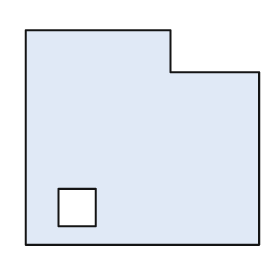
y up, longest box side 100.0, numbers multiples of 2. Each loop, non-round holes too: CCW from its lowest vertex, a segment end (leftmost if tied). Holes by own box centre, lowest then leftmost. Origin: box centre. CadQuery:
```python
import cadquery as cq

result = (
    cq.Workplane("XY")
    .moveTo(-50.0, -46.0)
    .lineTo(50.0, -46.0)
    .lineTo(50.0, 28.0)
    .lineTo(12.0, 28.0)
    .lineTo(12.0, 46.0)
    .lineTo(-50.0, 46.0)
    .close()
    .moveTo(-36.0, -38.0)
    .lineTo(-20.0, -38.0)
    .lineTo(-20.0, -22.0)
    .lineTo(-36.0, -22.0)
    .close()
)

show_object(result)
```